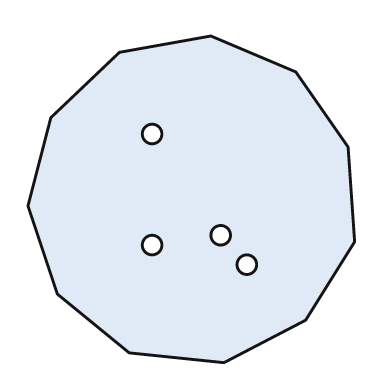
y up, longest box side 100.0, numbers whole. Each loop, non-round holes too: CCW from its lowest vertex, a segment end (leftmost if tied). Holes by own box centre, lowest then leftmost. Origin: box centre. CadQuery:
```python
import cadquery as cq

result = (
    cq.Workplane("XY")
    .moveTo(10.0, -50.0)
    .lineTo(35.0, -37.0)
    .lineTo(50.0, -13.0)
    .lineTo(48.0, 16.0)
    .lineTo(32.0, 39.0)
    .lineTo(6.0, 50.0)
    .lineTo(-22.0, 45.0)
    .lineTo(-43.0, 25.0)
    .lineTo(-50.0, -2.0)
    .lineTo(-41.0, -29.0)
    .lineTo(-19.0, -47.0)
    .close()
    .moveTo(17.0, -20.0)
    .circle(3.0)
    .moveTo(-12.0, -14.0)
    .circle(3.0)
    .moveTo(9.0, -11.0)
    .circle(3.0)
    .moveTo(-12.0, 20.0)
    .circle(3.0)
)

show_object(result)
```